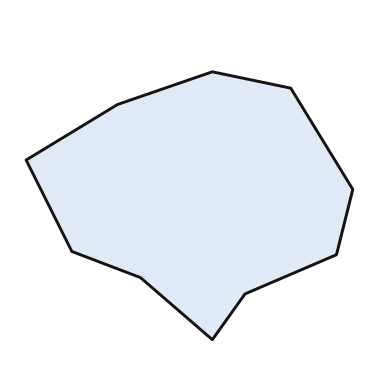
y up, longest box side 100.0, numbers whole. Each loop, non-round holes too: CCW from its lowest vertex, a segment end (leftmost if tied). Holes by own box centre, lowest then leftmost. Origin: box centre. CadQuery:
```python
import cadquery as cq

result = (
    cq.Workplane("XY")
    .moveTo(7.0, -41.0)
    .lineTo(17.0, -27.0)
    .lineTo(45.0, -15.0)
    .lineTo(50.0, 5.0)
    .lineTo(31.0, 36.0)
    .lineTo(7.0, 41.0)
    .lineTo(-22.0, 31.0)
    .lineTo(-50.0, 14.0)
    .lineTo(-36.0, -14.0)
    .lineTo(-15.0, -22.0)
    .close()
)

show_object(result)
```